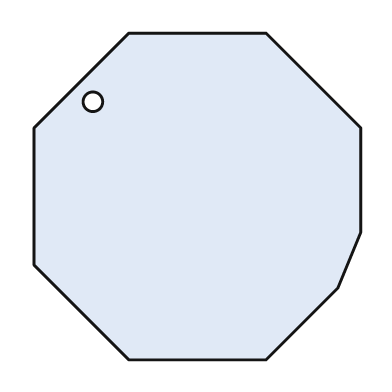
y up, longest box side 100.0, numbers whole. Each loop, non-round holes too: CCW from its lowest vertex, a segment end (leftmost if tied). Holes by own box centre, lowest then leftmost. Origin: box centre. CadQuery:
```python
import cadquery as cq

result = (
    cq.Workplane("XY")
    .moveTo(-21.0, -50.0)
    .lineTo(21.0, -50.0)
    .lineTo(43.0, -28.0)
    .lineTo(50.0, -11.0)
    .lineTo(50.0, 21.0)
    .lineTo(21.0, 50.0)
    .lineTo(-21.0, 50.0)
    .lineTo(-50.0, 21.0)
    .lineTo(-50.0, -21.0)
    .close()
    .moveTo(-32.0, 29.0)
    .circle(3.0)
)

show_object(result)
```